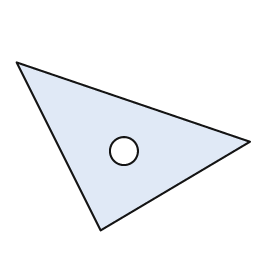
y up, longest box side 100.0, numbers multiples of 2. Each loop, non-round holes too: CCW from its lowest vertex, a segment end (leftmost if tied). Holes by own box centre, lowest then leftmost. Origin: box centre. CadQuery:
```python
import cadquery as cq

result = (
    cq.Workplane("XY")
    .moveTo(-14.0, -36.0)
    .lineTo(50.0, 2.0)
    .lineTo(-50.0, 36.0)
    .close()
    .moveTo(-4.0, -2.0)
    .circle(6.0)
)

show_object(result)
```